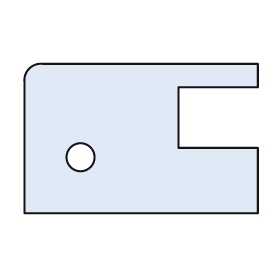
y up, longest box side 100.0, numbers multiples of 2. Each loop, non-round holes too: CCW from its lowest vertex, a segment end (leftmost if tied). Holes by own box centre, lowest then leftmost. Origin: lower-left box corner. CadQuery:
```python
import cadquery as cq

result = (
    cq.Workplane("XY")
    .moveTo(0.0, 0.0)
    .lineTo(100.0, 0.0)
    .lineTo(100.0, 28.0)
    .lineTo(66.0, 28.0)
    .lineTo(66.0, 54.0)
    .lineTo(100.0, 54.0)
    .lineTo(100.0, 64.0)
    .lineTo(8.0, 64.0)
    .threePointArc((2.0, 62.0), (0.0, 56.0))
    .close()
    .moveTo(24.0, 24.0)
    .circle(6.0)
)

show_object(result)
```